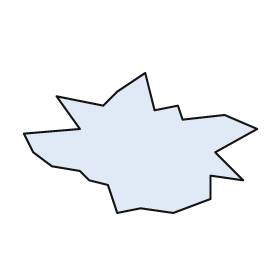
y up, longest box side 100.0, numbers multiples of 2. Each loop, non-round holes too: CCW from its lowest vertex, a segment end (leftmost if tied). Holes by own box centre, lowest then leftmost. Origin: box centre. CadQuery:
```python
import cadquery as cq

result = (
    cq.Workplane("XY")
    .moveTo(-10.0, -30.0)
    .lineTo(0.0, -28.0)
    .lineTo(14.0, -30.0)
    .lineTo(30.0, -24.0)
    .lineTo(30.0, -14.0)
    .lineTo(44.0, -16.0)
    .lineTo(32.0, -4.0)
    .lineTo(50.0, 6.0)
    .lineTo(36.0, 12.0)
    .lineTo(18.0, 10.0)
    .lineTo(16.0, 16.0)
    .lineTo(6.0, 14.0)
    .lineTo(2.0, 30.0)
    .lineTo(-10.0, 22.0)
    .lineTo(-16.0, 16.0)
    .lineTo(-36.0, 20.0)
    .lineTo(-26.0, 6.0)
    .lineTo(-50.0, 4.0)
    .lineTo(-46.0, -4.0)
    .lineTo(-38.0, -10.0)
    .lineTo(-26.0, -12.0)
    .lineTo(-22.0, -16.0)
    .lineTo(-14.0, -18.0)
    .close()
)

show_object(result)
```